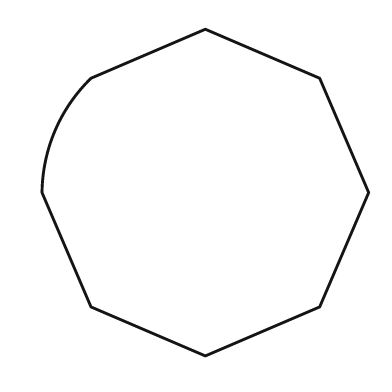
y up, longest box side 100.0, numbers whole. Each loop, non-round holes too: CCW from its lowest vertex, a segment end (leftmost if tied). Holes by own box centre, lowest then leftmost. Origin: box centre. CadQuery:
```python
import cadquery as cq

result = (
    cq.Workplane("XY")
    .moveTo(0.0, -50.0)
    .lineTo(35.0, -35.0)
    .lineTo(50.0, 0.0)
    .lineTo(35.0, 35.0)
    .lineTo(0.0, 50.0)
    .lineTo(-35.0, 35.0)
    .threePointArc((-46.0, 19.0), (-50.0, 0.0))
    .lineTo(-35.0, -35.0)
    .close()
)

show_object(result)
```